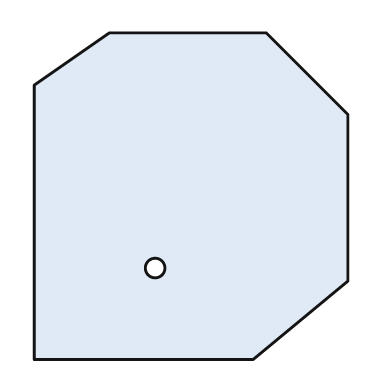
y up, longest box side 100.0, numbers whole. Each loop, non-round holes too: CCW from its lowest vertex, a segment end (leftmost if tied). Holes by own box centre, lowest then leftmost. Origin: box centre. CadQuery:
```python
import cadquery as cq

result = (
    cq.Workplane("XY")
    .moveTo(-48.0, -50.0)
    .lineTo(19.0, -50.0)
    .lineTo(48.0, -26.0)
    .lineTo(48.0, 25.0)
    .lineTo(23.0, 50.0)
    .lineTo(-25.0, 50.0)
    .lineTo(-48.0, 34.0)
    .close()
    .moveTo(-11.0, -22.0)
    .circle(3.0)
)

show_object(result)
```